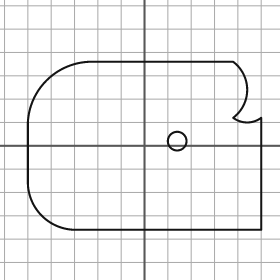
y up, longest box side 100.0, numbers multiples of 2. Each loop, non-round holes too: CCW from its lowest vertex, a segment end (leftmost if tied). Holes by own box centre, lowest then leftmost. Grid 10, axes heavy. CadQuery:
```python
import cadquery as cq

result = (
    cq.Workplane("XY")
    .moveTo(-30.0, -36.0)
    .lineTo(50.0, -36.0)
    .lineTo(50.0, 12.0)
    .threePointArc((44.0, 10.0), (38.0, 12.0))
    .threePointArc((44.0, 24.0), (38.0, 36.0))
    .lineTo(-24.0, 36.0)
    .threePointArc((-42.0, 28.0), (-50.0, 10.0))
    .lineTo(-50.0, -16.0)
    .threePointArc((-44.0, -30.0), (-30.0, -36.0))
    .close()
    .moveTo(14.0, 2.0)
    .circle(4.0)
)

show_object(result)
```